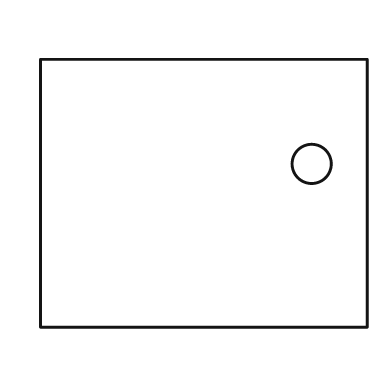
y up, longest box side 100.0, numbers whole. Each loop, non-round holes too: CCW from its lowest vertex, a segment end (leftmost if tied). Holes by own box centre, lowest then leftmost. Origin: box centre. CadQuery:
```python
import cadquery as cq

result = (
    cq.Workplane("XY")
    .moveTo(-50.0, -41.0)
    .lineTo(50.0, -41.0)
    .lineTo(50.0, 41.0)
    .lineTo(-50.0, 41.0)
    .close()
    .moveTo(33.0, 9.0)
    .circle(6.0)
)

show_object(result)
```